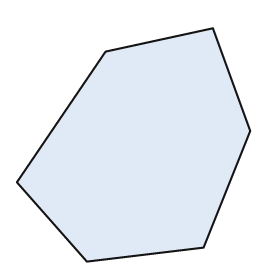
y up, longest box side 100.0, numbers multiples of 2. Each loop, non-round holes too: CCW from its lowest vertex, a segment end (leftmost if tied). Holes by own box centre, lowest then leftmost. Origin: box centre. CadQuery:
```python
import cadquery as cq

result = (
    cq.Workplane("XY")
    .moveTo(-20.0, -50.0)
    .lineTo(30.0, -44.0)
    .lineTo(50.0, 6.0)
    .lineTo(34.0, 50.0)
    .lineTo(-12.0, 40.0)
    .lineTo(-50.0, -16.0)
    .close()
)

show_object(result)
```